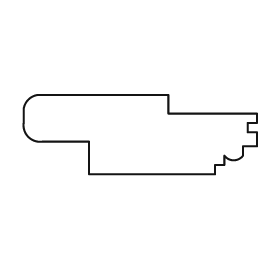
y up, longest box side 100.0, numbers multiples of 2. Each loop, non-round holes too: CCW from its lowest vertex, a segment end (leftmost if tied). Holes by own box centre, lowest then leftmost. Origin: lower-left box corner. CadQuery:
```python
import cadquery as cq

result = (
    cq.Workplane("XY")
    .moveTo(28.0, 0.0)
    .lineTo(82.0, 0.0)
    .lineTo(82.0, 4.0)
    .lineTo(86.0, 4.0)
    .lineTo(86.0, 8.0)
    .threePointArc((90.0, 6.0), (94.0, 8.0))
    .lineTo(94.0, 12.0)
    .lineTo(100.0, 12.0)
    .lineTo(100.0, 18.0)
    .lineTo(96.0, 18.0)
    .lineTo(96.0, 22.0)
    .lineTo(100.0, 22.0)
    .lineTo(100.0, 26.0)
    .lineTo(62.0, 26.0)
    .lineTo(62.0, 34.0)
    .lineTo(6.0, 34.0)
    .threePointArc((2.0, 32.0), (0.0, 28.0))
    .lineTo(0.0, 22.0)
    .threePointArc((2.0, 16.0), (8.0, 14.0))
    .lineTo(28.0, 14.0)
    .close()
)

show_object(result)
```